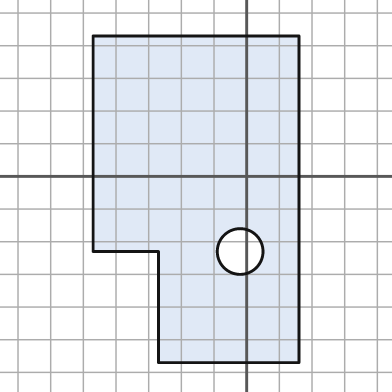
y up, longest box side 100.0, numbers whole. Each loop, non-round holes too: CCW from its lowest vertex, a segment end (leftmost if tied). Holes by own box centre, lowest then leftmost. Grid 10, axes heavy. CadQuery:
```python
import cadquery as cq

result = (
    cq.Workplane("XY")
    .moveTo(-27.0, -57.0)
    .lineTo(16.0, -57.0)
    .lineTo(16.0, 43.0)
    .lineTo(-47.0, 43.0)
    .lineTo(-47.0, -23.0)
    .lineTo(-27.0, -23.0)
    .close()
    .moveTo(-2.0, -23.0)
    .circle(7.0)
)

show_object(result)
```